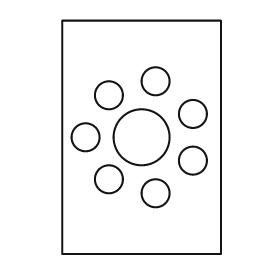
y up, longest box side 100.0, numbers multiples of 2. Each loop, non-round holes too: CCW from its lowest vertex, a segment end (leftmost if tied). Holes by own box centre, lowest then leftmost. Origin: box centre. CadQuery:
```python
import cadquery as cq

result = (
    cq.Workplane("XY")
    .moveTo(-34.0, -50.0)
    .lineTo(34.0, -50.0)
    .lineTo(34.0, 50.0)
    .lineTo(-34.0, 50.0)
    .close()
    .moveTo(6.0, -24.0)
    .circle(6.0)
    .moveTo(-14.0, -18.0)
    .circle(6.0)
    .moveTo(22.0, -10.0)
    .circle(6.0)
    .moveTo(-24.0, 0.0)
    .circle(6.0)
    .moveTo(0.0, 0.0)
    .circle(12.0)
    .moveTo(22.0, 10.0)
    .circle(6.0)
    .moveTo(-14.0, 18.0)
    .circle(6.0)
    .moveTo(6.0, 24.0)
    .circle(6.0)
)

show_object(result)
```